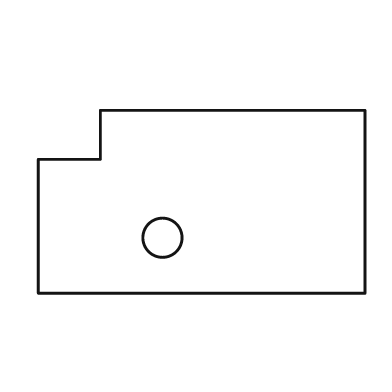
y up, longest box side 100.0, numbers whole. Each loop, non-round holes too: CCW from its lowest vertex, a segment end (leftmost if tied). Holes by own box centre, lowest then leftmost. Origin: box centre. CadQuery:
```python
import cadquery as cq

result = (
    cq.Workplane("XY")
    .moveTo(-50.0, -28.0)
    .lineTo(50.0, -28.0)
    .lineTo(50.0, 28.0)
    .lineTo(-31.0, 28.0)
    .lineTo(-31.0, 13.0)
    .lineTo(-50.0, 13.0)
    .close()
    .moveTo(-12.0, -11.0)
    .circle(6.0)
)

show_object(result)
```